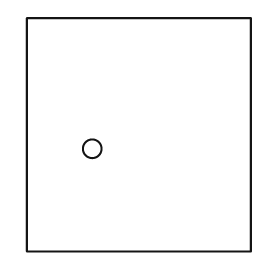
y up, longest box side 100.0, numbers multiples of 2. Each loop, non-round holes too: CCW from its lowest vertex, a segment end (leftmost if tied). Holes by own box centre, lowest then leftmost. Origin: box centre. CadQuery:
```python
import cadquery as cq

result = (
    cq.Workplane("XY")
    .moveTo(-48.0, -50.0)
    .lineTo(48.0, -50.0)
    .lineTo(48.0, 50.0)
    .lineTo(-48.0, 50.0)
    .close()
    .moveTo(-20.0, -6.0)
    .circle(4.0)
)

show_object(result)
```